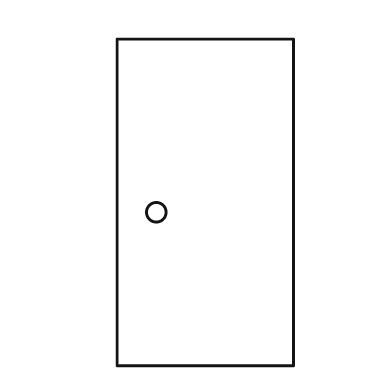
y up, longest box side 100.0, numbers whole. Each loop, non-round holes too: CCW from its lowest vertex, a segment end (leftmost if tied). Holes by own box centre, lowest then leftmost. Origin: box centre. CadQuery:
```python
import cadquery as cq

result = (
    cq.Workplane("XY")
    .moveTo(-27.0, -50.0)
    .lineTo(27.0, -50.0)
    .lineTo(27.0, 50.0)
    .lineTo(-27.0, 50.0)
    .close()
    .moveTo(-15.0, -3.0)
    .circle(3.0)
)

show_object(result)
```